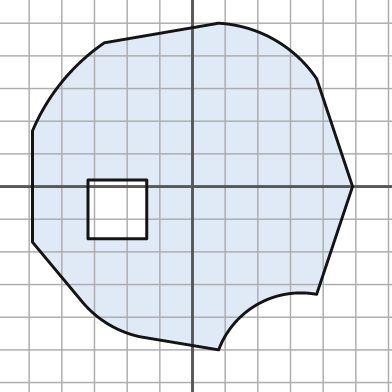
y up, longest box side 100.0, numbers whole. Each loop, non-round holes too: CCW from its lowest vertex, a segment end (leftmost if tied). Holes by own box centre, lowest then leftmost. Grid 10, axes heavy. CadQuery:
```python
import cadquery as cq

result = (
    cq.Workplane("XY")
    .moveTo(8.0, -50.0)
    .threePointArc((20.0, -36.0), (38.0, -33.0))
    .lineTo(49.0, 0.0)
    .lineTo(38.0, 33.0)
    .threePointArc((25.0, 45.0), (8.0, 50.0))
    .lineTo(-27.0, 44.0)
    .threePointArc((-40.0, 32.0), (-49.0, 17.0))
    .lineTo(-49.0, -17.0)
    .lineTo(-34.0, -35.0)
    .threePointArc((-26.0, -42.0), (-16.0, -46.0))
    .close()
    .moveTo(-32.0, -16.0)
    .lineTo(-14.0, -16.0)
    .lineTo(-14.0, 2.0)
    .lineTo(-32.0, 2.0)
    .close()
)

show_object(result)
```